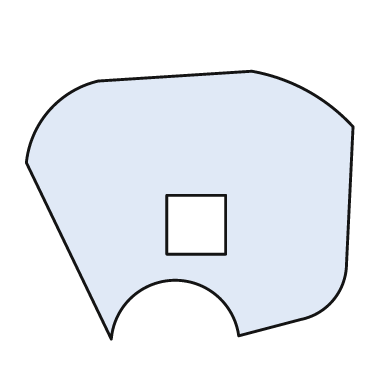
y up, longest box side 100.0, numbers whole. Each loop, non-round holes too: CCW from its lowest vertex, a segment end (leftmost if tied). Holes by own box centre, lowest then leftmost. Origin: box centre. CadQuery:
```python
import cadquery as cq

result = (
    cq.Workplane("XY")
    .moveTo(-24.0, -41.0)
    .threePointArc((-5.0, -23.0), (15.0, -40.0))
    .lineTo(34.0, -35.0)
    .threePointArc((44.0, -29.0), (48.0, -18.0))
    .lineTo(50.0, 24.0)
    .threePointArc((36.0, 35.0), (19.0, 41.0))
    .lineTo(-28.0, 38.0)
    .threePointArc((-43.0, 29.0), (-50.0, 13.0))
    .close()
    .moveTo(-7.0, -15.0)
    .lineTo(11.0, -15.0)
    .lineTo(11.0, 3.0)
    .lineTo(-7.0, 3.0)
    .close()
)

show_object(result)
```